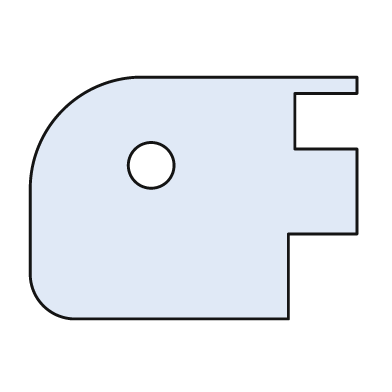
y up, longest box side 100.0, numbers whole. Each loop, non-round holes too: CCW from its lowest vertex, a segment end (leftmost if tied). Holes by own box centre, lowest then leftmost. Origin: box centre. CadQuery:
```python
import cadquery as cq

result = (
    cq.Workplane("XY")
    .moveTo(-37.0, -37.0)
    .lineTo(29.0, -37.0)
    .lineTo(29.0, -11.0)
    .lineTo(50.0, -11.0)
    .lineTo(50.0, 15.0)
    .lineTo(31.0, 15.0)
    .lineTo(31.0, 32.0)
    .lineTo(50.0, 32.0)
    .lineTo(50.0, 37.0)
    .lineTo(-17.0, 37.0)
    .threePointArc((-40.0, 27.0), (-50.0, 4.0))
    .lineTo(-50.0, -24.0)
    .threePointArc((-46.0, -33.0), (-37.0, -37.0))
    .close()
    .moveTo(-13.0, 10.0)
    .circle(7.0)
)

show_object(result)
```